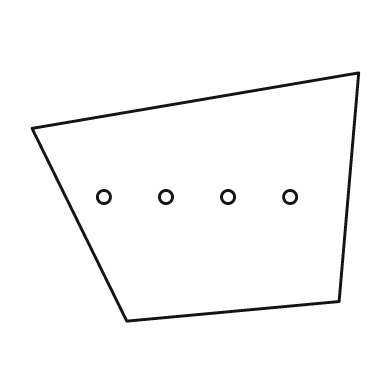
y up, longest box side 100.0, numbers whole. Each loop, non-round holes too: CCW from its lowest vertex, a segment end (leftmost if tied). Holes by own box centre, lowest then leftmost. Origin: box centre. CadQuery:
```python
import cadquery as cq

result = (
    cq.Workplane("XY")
    .moveTo(-21.0, -38.0)
    .lineTo(44.0, -32.0)
    .lineTo(50.0, 38.0)
    .lineTo(-50.0, 21.0)
    .close()
    .moveTo(-28.0, 0.0)
    .circle(2.0)
    .moveTo(-9.0, 0.0)
    .circle(2.0)
    .moveTo(10.0, 0.0)
    .circle(2.0)
    .moveTo(29.0, 0.0)
    .circle(2.0)
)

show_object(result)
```